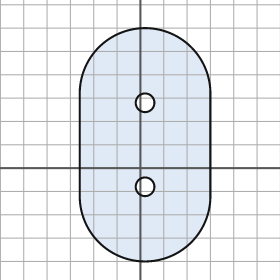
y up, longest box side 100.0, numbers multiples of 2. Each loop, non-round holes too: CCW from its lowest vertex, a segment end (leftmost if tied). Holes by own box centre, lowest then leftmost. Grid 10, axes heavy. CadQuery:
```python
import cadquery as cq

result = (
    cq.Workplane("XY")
    .moveTo(-26.0, -12.0)
    .threePointArc((2.0, -40.0), (30.0, -12.0))
    .lineTo(30.0, 32.0)
    .threePointArc((2.0, 60.0), (-26.0, 32.0))
    .close()
    .moveTo(2.0, -8.0)
    .circle(4.0)
    .moveTo(2.0, 28.0)
    .circle(4.0)
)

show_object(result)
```